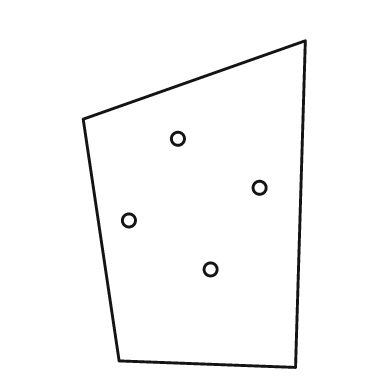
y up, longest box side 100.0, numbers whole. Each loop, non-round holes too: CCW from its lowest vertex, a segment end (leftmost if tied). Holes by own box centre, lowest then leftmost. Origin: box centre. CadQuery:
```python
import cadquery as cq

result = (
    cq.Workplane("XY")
    .moveTo(31.0, -50.0)
    .lineTo(34.0, 50.0)
    .lineTo(-34.0, 26.0)
    .lineTo(-23.0, -48.0)
    .close()
    .moveTo(5.0, -20.0)
    .circle(2.0)
    .moveTo(-20.0, -5.0)
    .circle(2.0)
    .moveTo(20.0, 5.0)
    .circle(2.0)
    .moveTo(-5.0, 20.0)
    .circle(2.0)
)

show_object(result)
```